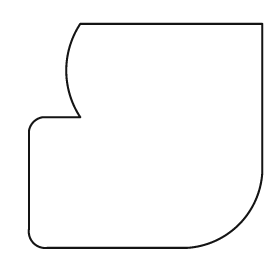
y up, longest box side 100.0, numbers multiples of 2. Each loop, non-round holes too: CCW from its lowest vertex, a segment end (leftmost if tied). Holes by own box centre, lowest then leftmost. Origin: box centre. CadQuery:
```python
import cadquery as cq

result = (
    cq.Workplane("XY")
    .moveTo(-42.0, -48.0)
    .lineTo(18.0, -48.0)
    .threePointArc((40.0, -38.0), (50.0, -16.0))
    .lineTo(50.0, 48.0)
    .lineTo(-28.0, 48.0)
    .threePointArc((-34.0, 28.0), (-28.0, 8.0))
    .lineTo(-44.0, 8.0)
    .threePointArc((-48.0, 6.0), (-50.0, 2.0))
    .lineTo(-50.0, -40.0)
    .threePointArc((-48.0, -46.0), (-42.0, -48.0))
    .close()
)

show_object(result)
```